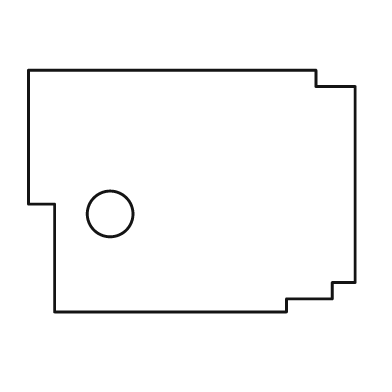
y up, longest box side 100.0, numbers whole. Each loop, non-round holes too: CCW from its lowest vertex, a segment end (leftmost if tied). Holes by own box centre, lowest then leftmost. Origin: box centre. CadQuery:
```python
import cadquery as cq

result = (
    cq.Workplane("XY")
    .moveTo(-42.0, -37.0)
    .lineTo(29.0, -37.0)
    .lineTo(29.0, -33.0)
    .lineTo(43.0, -33.0)
    .lineTo(43.0, -28.0)
    .lineTo(50.0, -28.0)
    .lineTo(50.0, 32.0)
    .lineTo(38.0, 32.0)
    .lineTo(38.0, 37.0)
    .lineTo(-50.0, 37.0)
    .lineTo(-50.0, -4.0)
    .lineTo(-42.0, -4.0)
    .close()
    .moveTo(-25.0, -7.0)
    .circle(7.0)
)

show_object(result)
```